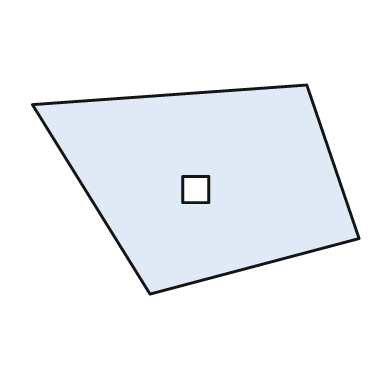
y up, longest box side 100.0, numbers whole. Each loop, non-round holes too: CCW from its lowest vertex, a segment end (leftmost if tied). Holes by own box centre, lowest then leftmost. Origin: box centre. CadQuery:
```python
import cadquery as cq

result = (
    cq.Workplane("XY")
    .moveTo(-14.0, -32.0)
    .lineTo(50.0, -15.0)
    .lineTo(34.0, 32.0)
    .lineTo(-50.0, 26.0)
    .close()
    .moveTo(-4.0, -4.0)
    .lineTo(4.0, -4.0)
    .lineTo(4.0, 4.0)
    .lineTo(-4.0, 4.0)
    .close()
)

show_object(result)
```